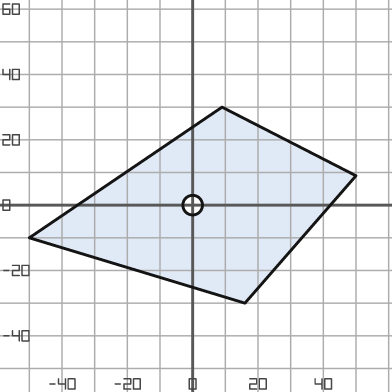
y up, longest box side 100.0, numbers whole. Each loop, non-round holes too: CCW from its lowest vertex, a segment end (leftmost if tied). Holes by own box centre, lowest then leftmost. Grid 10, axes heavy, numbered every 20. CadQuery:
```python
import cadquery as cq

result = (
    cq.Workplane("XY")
    .moveTo(16.0, -30.0)
    .lineTo(50.0, 9.0)
    .lineTo(9.0, 30.0)
    .lineTo(-50.0, -10.0)
    .close()
    .moveTo(0.0, 0.0)
    .circle(3.0)
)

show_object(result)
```